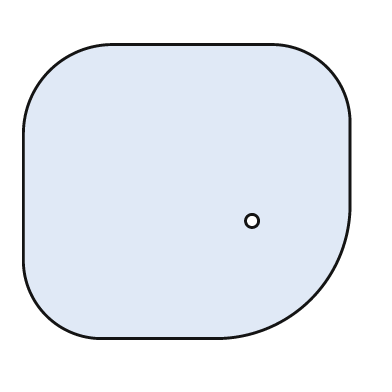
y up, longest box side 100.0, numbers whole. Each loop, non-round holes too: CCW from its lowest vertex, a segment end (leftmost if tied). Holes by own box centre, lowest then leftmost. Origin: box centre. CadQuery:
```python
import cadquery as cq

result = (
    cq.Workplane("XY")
    .moveTo(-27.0, -45.0)
    .lineTo(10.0, -45.0)
    .threePointArc((38.0, -33.0), (50.0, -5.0))
    .lineTo(50.0, 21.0)
    .threePointArc((43.0, 38.0), (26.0, 45.0))
    .lineTo(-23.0, 45.0)
    .threePointArc((-42.0, 37.0), (-50.0, 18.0))
    .lineTo(-50.0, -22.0)
    .threePointArc((-43.0, -38.0), (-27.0, -45.0))
    .close()
    .moveTo(20.0, -9.0)
    .circle(2.0)
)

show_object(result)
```